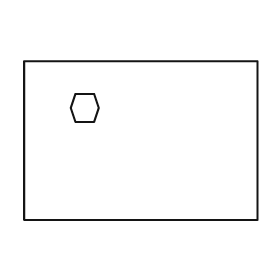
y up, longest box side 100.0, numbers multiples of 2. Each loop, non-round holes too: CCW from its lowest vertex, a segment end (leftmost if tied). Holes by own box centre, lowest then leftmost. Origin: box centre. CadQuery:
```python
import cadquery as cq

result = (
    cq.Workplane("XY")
    .moveTo(-50.0, -34.0)
    .lineTo(50.0, -34.0)
    .lineTo(50.0, 34.0)
    .lineTo(-50.0, 34.0)
    .close()
    .moveTo(-28.0, 8.0)
    .lineTo(-20.0, 8.0)
    .lineTo(-18.0, 14.0)
    .lineTo(-20.0, 20.0)
    .lineTo(-28.0, 20.0)
    .lineTo(-30.0, 14.0)
    .close()
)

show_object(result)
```